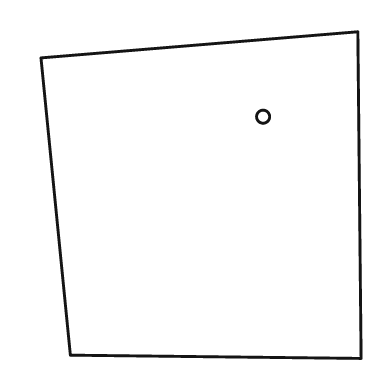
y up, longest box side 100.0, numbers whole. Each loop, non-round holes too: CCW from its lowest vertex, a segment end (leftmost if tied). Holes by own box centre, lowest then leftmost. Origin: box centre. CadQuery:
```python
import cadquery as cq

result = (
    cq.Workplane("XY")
    .moveTo(49.0, -50.0)
    .lineTo(48.0, 50.0)
    .lineTo(-49.0, 42.0)
    .lineTo(-40.0, -49.0)
    .close()
    .moveTo(19.0, 24.0)
    .circle(2.0)
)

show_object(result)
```